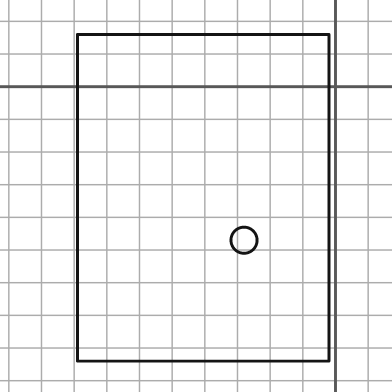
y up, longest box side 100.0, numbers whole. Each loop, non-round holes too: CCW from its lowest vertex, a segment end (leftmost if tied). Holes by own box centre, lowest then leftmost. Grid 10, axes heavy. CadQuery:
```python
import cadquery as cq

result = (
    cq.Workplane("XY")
    .moveTo(-79.0, -84.0)
    .lineTo(-2.0, -84.0)
    .lineTo(-2.0, 16.0)
    .lineTo(-79.0, 16.0)
    .close()
    .moveTo(-28.0, -47.0)
    .circle(4.0)
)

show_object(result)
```